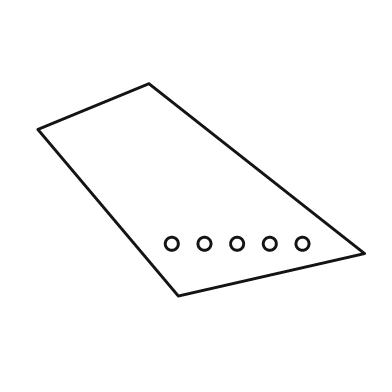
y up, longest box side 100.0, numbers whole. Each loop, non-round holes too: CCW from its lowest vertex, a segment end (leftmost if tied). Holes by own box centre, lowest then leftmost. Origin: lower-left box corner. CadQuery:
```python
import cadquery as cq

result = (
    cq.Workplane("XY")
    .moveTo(43.0, 0.0)
    .lineTo(100.0, 13.0)
    .lineTo(34.0, 65.0)
    .lineTo(0.0, 51.0)
    .close()
    .moveTo(41.0, 16.0)
    .circle(2.0)
    .moveTo(51.0, 16.0)
    .circle(2.0)
    .moveTo(61.0, 16.0)
    .circle(2.0)
    .moveTo(71.0, 16.0)
    .circle(2.0)
    .moveTo(81.0, 16.0)
    .circle(2.0)
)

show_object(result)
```